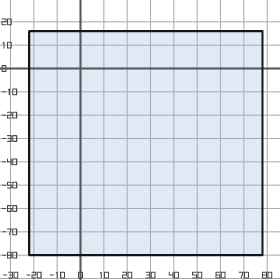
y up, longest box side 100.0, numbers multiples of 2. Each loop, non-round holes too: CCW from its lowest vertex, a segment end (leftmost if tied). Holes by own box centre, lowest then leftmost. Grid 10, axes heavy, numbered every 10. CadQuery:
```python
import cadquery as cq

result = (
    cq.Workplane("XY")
    .moveTo(-22.0, -80.0)
    .lineTo(78.0, -80.0)
    .lineTo(78.0, 16.0)
    .lineTo(-22.0, 16.0)
    .close()
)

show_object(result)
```